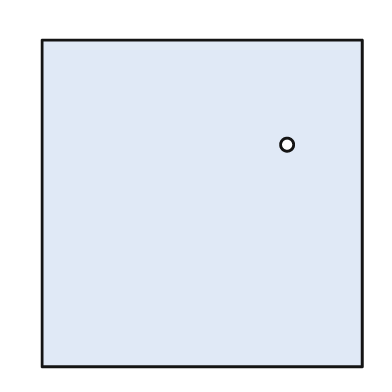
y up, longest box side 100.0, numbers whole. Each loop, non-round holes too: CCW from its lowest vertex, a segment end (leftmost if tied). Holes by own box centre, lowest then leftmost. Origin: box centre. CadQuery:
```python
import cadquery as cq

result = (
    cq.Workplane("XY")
    .moveTo(-49.0, -50.0)
    .lineTo(49.0, -50.0)
    .lineTo(49.0, 50.0)
    .lineTo(-49.0, 50.0)
    .close()
    .moveTo(26.0, 18.0)
    .circle(2.0)
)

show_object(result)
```